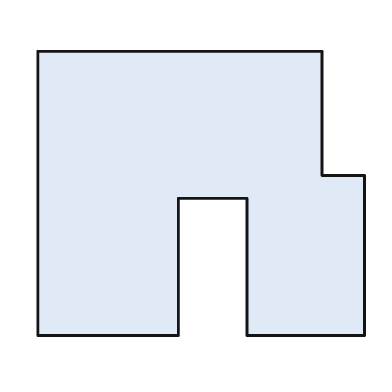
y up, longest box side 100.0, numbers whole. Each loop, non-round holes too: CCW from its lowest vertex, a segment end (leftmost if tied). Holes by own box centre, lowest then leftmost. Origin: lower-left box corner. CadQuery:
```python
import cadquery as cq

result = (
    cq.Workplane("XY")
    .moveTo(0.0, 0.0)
    .lineTo(43.0, 0.0)
    .lineTo(43.0, 42.0)
    .lineTo(64.0, 42.0)
    .lineTo(64.0, 0.0)
    .lineTo(100.0, 0.0)
    .lineTo(100.0, 49.0)
    .lineTo(87.0, 49.0)
    .lineTo(87.0, 87.0)
    .lineTo(0.0, 87.0)
    .close()
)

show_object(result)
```